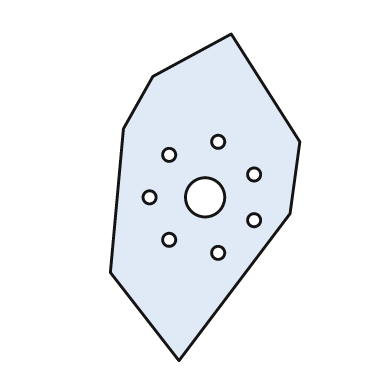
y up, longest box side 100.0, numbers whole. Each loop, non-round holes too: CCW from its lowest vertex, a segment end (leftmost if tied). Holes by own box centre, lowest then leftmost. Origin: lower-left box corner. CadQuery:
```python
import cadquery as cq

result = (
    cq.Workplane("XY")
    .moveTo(21.0, 0.0)
    .lineTo(55.0, 45.0)
    .lineTo(58.0, 67.0)
    .lineTo(37.0, 100.0)
    .lineTo(13.0, 87.0)
    .lineTo(4.0, 71.0)
    .lineTo(0.0, 27.0)
    .close()
    .moveTo(33.0, 33.0)
    .circle(2.0)
    .moveTo(18.0, 37.0)
    .circle(2.0)
    .moveTo(44.0, 43.0)
    .circle(2.0)
    .moveTo(12.0, 50.0)
    .circle(2.0)
    .moveTo(29.0, 50.0)
    .circle(6.0)
    .moveTo(44.0, 57.0)
    .circle(2.0)
    .moveTo(18.0, 63.0)
    .circle(2.0)
    .moveTo(33.0, 67.0)
    .circle(2.0)
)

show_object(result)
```